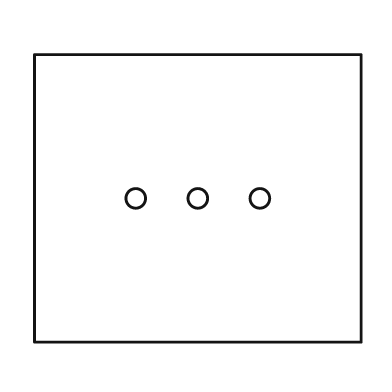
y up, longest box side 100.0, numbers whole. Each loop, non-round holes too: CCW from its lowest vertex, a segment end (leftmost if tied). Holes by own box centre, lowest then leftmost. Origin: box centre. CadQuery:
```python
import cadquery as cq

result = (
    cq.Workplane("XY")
    .moveTo(-50.0, -44.0)
    .lineTo(50.0, -44.0)
    .lineTo(50.0, 44.0)
    .lineTo(-50.0, 44.0)
    .close()
    .moveTo(-19.0, 0.0)
    .circle(3.0)
    .moveTo(0.0, 0.0)
    .circle(3.0)
    .moveTo(19.0, 0.0)
    .circle(3.0)
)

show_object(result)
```